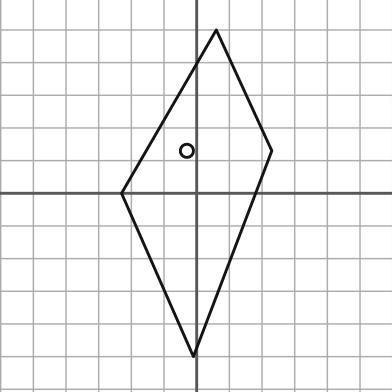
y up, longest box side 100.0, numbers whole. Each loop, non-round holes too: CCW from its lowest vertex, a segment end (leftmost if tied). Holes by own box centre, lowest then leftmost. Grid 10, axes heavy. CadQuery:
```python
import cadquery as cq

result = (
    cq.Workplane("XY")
    .moveTo(-1.0, -50.0)
    .lineTo(23.0, 13.0)
    .lineTo(6.0, 50.0)
    .lineTo(-23.0, 0.0)
    .close()
    .moveTo(-3.0, 13.0)
    .circle(2.0)
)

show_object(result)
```